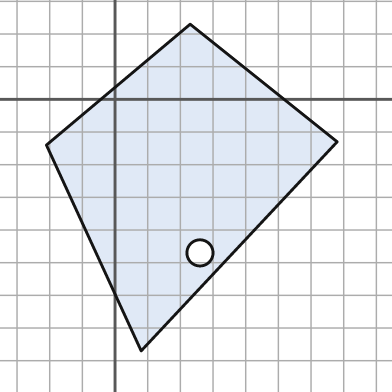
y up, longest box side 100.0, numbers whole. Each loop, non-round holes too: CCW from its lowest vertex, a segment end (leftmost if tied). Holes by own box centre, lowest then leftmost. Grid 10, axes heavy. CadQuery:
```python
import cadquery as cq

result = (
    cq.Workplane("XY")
    .moveTo(8.0, -77.0)
    .lineTo(68.0, -13.0)
    .lineTo(23.0, 23.0)
    .lineTo(-21.0, -14.0)
    .close()
    .moveTo(26.0, -47.0)
    .circle(4.0)
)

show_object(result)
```